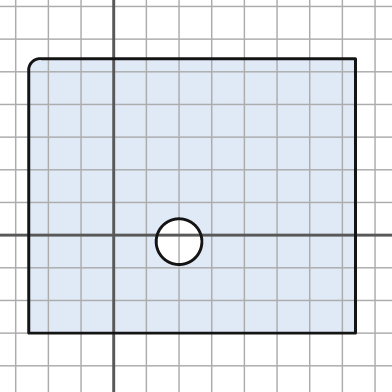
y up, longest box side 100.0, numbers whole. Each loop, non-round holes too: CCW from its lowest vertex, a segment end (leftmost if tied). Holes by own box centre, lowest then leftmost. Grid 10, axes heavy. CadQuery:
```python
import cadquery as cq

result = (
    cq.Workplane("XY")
    .moveTo(-26.0, -30.0)
    .lineTo(74.0, -30.0)
    .lineTo(74.0, 54.0)
    .lineTo(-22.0, 54.0)
    .threePointArc((-25.0, 53.0), (-26.0, 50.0))
    .close()
    .moveTo(20.0, -2.0)
    .circle(7.0)
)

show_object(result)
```